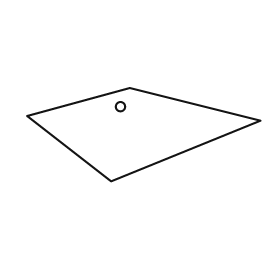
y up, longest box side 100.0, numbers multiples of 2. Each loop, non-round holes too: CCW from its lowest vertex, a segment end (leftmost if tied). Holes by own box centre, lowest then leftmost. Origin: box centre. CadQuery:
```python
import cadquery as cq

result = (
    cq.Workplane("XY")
    .moveTo(-14.0, -20.0)
    .lineTo(50.0, 6.0)
    .lineTo(-6.0, 20.0)
    .lineTo(-50.0, 8.0)
    .close()
    .moveTo(-10.0, 12.0)
    .circle(2.0)
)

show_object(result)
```